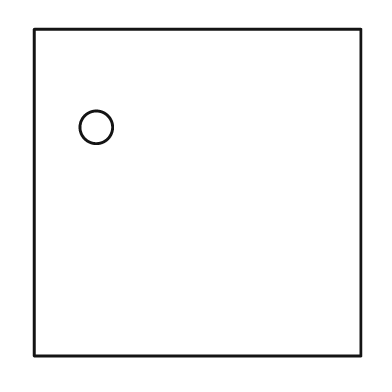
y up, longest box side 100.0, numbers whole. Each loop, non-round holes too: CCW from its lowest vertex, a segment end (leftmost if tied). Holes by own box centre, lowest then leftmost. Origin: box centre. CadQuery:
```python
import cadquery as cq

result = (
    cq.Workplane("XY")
    .moveTo(-50.0, -50.0)
    .lineTo(50.0, -50.0)
    .lineTo(50.0, 50.0)
    .lineTo(-50.0, 50.0)
    .close()
    .moveTo(-31.0, 20.0)
    .circle(5.0)
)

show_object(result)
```